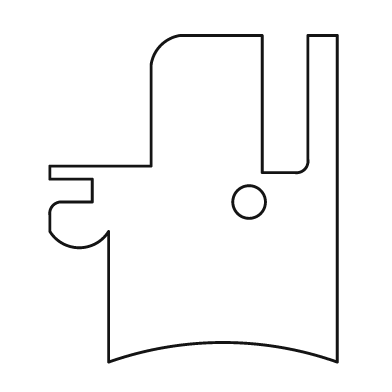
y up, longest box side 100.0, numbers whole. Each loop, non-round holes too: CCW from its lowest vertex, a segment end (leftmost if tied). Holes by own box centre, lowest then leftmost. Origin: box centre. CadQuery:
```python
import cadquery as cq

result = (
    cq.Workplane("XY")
    .moveTo(-26.0, -50.0)
    .threePointArc((9.0, -44.0), (44.0, -50.0))
    .lineTo(44.0, 50.0)
    .lineTo(35.0, 50.0)
    .lineTo(35.0, 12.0)
    .threePointArc((34.0, 9.0), (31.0, 8.0))
    .lineTo(21.0, 8.0)
    .lineTo(21.0, 50.0)
    .lineTo(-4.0, 50.0)
    .threePointArc((-10.0, 47.0), (-13.0, 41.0))
    .lineTo(-13.0, 10.0)
    .lineTo(-44.0, 10.0)
    .lineTo(-44.0, 6.0)
    .lineTo(-31.0, 6.0)
    .lineTo(-31.0, -1.0)
    .lineTo(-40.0, -1.0)
    .threePointArc((-43.0, -2.0), (-44.0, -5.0))
    .lineTo(-44.0, -10.0)
    .threePointArc((-35.0, -15.0), (-26.0, -10.0))
    .close()
    .moveTo(17.0, -1.0)
    .circle(5.0)
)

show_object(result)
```